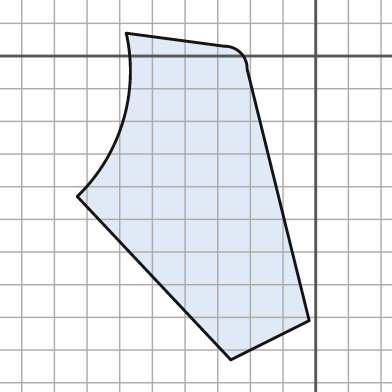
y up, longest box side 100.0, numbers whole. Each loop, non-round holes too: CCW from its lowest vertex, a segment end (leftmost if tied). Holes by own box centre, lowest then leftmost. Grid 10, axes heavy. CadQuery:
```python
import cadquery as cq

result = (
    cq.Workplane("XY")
    .moveTo(-26.0, -93.0)
    .lineTo(-2.0, -81.0)
    .lineTo(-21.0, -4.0)
    .threePointArc((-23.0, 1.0), (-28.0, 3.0))
    .lineTo(-58.0, 7.0)
    .threePointArc((-59.0, -20.0), (-73.0, -43.0))
    .close()
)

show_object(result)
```